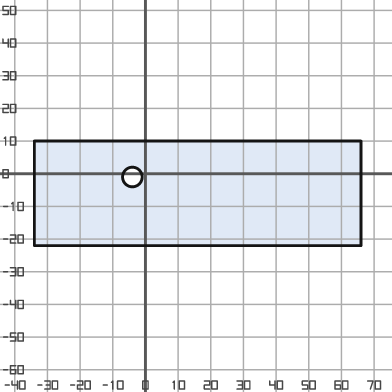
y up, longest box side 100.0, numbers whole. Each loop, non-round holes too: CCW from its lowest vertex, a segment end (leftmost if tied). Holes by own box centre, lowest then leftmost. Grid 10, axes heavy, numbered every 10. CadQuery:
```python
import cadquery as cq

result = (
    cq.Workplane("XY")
    .moveTo(-34.0, -22.0)
    .lineTo(66.0, -22.0)
    .lineTo(66.0, 10.0)
    .lineTo(-34.0, 10.0)
    .close()
    .moveTo(-4.0, -1.0)
    .circle(3.0)
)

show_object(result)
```